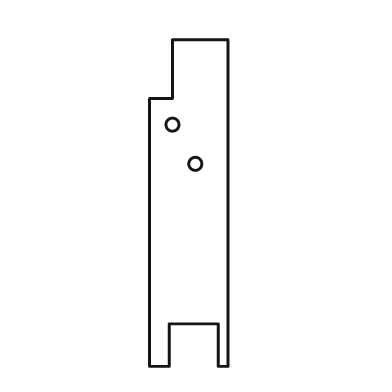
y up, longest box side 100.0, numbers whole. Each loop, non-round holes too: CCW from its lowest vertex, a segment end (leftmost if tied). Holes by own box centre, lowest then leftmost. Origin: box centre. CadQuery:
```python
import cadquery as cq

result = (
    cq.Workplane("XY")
    .moveTo(-12.0, -50.0)
    .lineTo(-6.0, -50.0)
    .lineTo(-6.0, -37.0)
    .lineTo(9.0, -37.0)
    .lineTo(9.0, -50.0)
    .lineTo(12.0, -50.0)
    .lineTo(12.0, 50.0)
    .lineTo(-5.0, 50.0)
    .lineTo(-5.0, 32.0)
    .lineTo(-12.0, 32.0)
    .close()
    .moveTo(2.0, 12.0)
    .circle(2.0)
    .moveTo(-5.0, 24.0)
    .circle(2.0)
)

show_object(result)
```